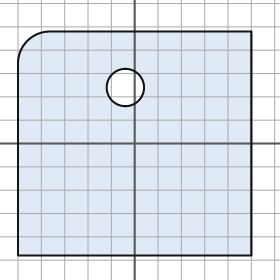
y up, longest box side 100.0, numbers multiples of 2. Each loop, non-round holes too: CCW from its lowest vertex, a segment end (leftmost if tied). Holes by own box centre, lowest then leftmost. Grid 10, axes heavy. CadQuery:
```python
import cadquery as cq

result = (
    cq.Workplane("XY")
    .moveTo(-50.0, -48.0)
    .lineTo(50.0, -48.0)
    .lineTo(50.0, 48.0)
    .lineTo(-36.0, 48.0)
    .threePointArc((-46.0, 44.0), (-50.0, 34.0))
    .close()
    .moveTo(-4.0, 24.0)
    .circle(8.0)
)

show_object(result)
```